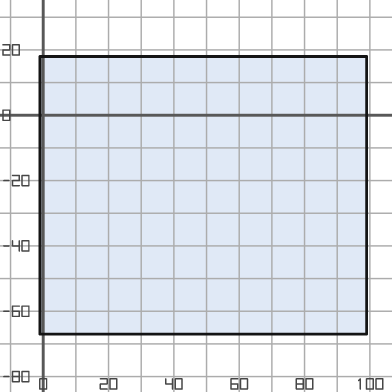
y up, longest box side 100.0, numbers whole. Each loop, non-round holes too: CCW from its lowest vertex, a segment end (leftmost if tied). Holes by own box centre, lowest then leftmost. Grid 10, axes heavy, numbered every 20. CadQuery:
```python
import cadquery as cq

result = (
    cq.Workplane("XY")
    .moveTo(-1.0, -67.0)
    .lineTo(99.0, -67.0)
    .lineTo(99.0, 18.0)
    .lineTo(-1.0, 18.0)
    .close()
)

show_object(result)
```